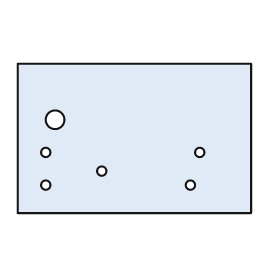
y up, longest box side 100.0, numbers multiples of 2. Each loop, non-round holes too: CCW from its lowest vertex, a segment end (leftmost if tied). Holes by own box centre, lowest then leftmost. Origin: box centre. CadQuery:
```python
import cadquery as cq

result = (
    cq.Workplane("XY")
    .moveTo(-50.0, -32.0)
    .lineTo(50.0, -32.0)
    .lineTo(50.0, 32.0)
    .lineTo(-50.0, 32.0)
    .close()
    .moveTo(-38.0, -20.0)
    .circle(2.0)
    .moveTo(24.0, -20.0)
    .circle(2.0)
    .moveTo(-14.0, -14.0)
    .circle(2.0)
    .moveTo(-38.0, -6.0)
    .circle(2.0)
    .moveTo(28.0, -6.0)
    .circle(2.0)
    .moveTo(-34.0, 8.0)
    .circle(4.0)
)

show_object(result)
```